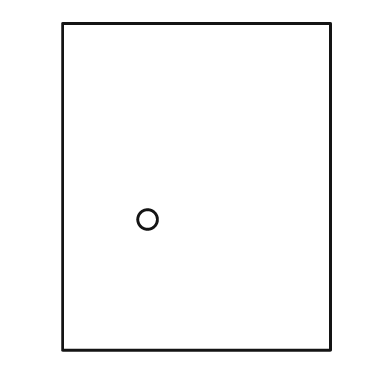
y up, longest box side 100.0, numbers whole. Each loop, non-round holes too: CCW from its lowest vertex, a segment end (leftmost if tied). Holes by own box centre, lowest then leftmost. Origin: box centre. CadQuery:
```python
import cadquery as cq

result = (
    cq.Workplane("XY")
    .moveTo(-41.0, -50.0)
    .lineTo(41.0, -50.0)
    .lineTo(41.0, 50.0)
    .lineTo(-41.0, 50.0)
    .close()
    .moveTo(-15.0, -10.0)
    .circle(3.0)
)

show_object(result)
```